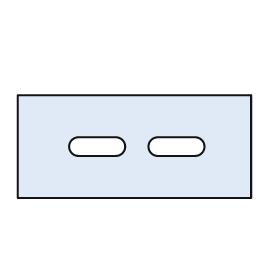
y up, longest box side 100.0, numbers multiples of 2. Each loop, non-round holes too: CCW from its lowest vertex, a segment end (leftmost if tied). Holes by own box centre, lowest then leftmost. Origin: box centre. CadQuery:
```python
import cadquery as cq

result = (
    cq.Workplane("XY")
    .moveTo(-50.0, -22.0)
    .lineTo(50.0, -22.0)
    .lineTo(50.0, 22.0)
    .lineTo(-50.0, 22.0)
    .close()
    .moveTo(-24.0, -4.0)
    .lineTo(-8.0, -4.0)
    .threePointArc((-4.0, 0.0), (-8.0, 4.0))
    .lineTo(-24.0, 4.0)
    .threePointArc((-28.0, 0.0), (-24.0, -4.0))
    .close()
    .moveTo(10.0, -4.0)
    .lineTo(26.0, -4.0)
    .threePointArc((30.0, 0.0), (26.0, 4.0))
    .lineTo(10.0, 4.0)
    .threePointArc((6.0, 0.0), (10.0, -4.0))
    .close()
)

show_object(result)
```